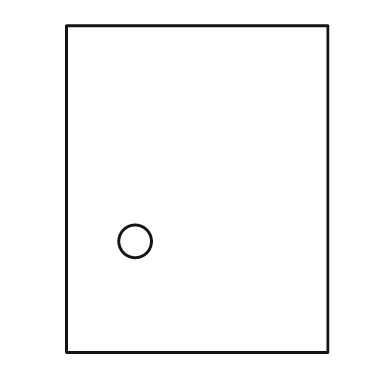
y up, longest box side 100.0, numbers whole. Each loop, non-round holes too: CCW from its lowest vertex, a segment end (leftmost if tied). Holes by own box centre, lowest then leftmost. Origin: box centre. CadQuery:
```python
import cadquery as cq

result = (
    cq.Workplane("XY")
    .moveTo(-40.0, -50.0)
    .lineTo(40.0, -50.0)
    .lineTo(40.0, 50.0)
    .lineTo(-40.0, 50.0)
    .close()
    .moveTo(-19.0, -16.0)
    .circle(5.0)
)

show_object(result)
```